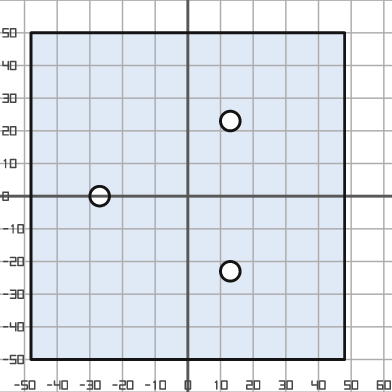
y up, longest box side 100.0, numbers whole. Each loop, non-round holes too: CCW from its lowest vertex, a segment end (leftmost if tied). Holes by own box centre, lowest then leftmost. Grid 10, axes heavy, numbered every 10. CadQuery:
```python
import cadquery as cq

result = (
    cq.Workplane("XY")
    .moveTo(-48.0, -50.0)
    .lineTo(48.0, -50.0)
    .lineTo(48.0, 50.0)
    .lineTo(-48.0, 50.0)
    .close()
    .moveTo(13.0, -23.0)
    .circle(3.0)
    .moveTo(-27.0, 0.0)
    .circle(3.0)
    .moveTo(13.0, 23.0)
    .circle(3.0)
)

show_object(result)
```